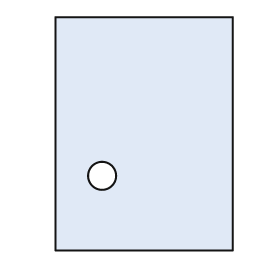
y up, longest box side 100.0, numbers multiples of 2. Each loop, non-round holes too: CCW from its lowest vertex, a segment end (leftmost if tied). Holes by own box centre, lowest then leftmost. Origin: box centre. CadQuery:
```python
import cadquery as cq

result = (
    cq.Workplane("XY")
    .moveTo(-38.0, -50.0)
    .lineTo(38.0, -50.0)
    .lineTo(38.0, 50.0)
    .lineTo(-38.0, 50.0)
    .close()
    .moveTo(-18.0, -18.0)
    .circle(6.0)
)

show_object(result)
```